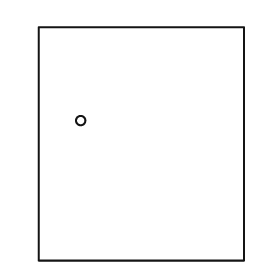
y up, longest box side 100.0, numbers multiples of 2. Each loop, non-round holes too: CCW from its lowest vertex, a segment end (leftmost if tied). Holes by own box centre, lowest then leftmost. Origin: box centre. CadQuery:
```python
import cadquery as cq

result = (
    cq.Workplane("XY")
    .moveTo(-44.0, -50.0)
    .lineTo(44.0, -50.0)
    .lineTo(44.0, 50.0)
    .lineTo(-44.0, 50.0)
    .close()
    .moveTo(-26.0, 10.0)
    .circle(2.0)
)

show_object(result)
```